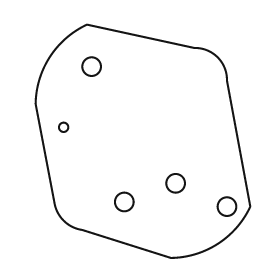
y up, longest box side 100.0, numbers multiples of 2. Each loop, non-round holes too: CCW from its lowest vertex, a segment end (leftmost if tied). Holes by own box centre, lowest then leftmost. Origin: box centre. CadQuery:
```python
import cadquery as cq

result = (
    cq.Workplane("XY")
    .moveTo(12.0, -50.0)
    .threePointArc((32.0, -44.0), (46.0, -28.0))
    .lineTo(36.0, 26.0)
    .threePointArc((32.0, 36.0), (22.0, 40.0))
    .lineTo(-24.0, 50.0)
    .threePointArc((-40.0, 36.0), (-46.0, 16.0))
    .lineTo(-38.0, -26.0)
    .threePointArc((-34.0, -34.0), (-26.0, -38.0))
    .close()
    .moveTo(36.0, -28.0)
    .circle(4.0)
    .moveTo(-8.0, -26.0)
    .circle(4.0)
    .moveTo(14.0, -18.0)
    .circle(4.0)
    .moveTo(-34.0, 6.0)
    .circle(2.0)
    .moveTo(-22.0, 32.0)
    .circle(4.0)
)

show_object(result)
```